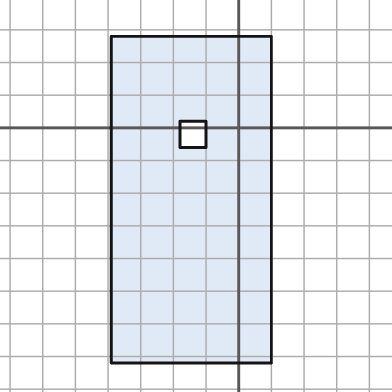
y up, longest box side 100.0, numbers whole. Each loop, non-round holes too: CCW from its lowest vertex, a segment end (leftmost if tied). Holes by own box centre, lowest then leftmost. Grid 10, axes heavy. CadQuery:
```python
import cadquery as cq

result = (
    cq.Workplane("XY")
    .moveTo(-39.0, -72.0)
    .lineTo(10.0, -72.0)
    .lineTo(10.0, 28.0)
    .lineTo(-39.0, 28.0)
    .close()
    .moveTo(-18.0, -6.0)
    .lineTo(-10.0, -6.0)
    .lineTo(-10.0, 2.0)
    .lineTo(-18.0, 2.0)
    .close()
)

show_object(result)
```